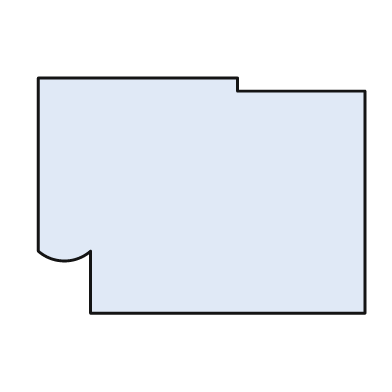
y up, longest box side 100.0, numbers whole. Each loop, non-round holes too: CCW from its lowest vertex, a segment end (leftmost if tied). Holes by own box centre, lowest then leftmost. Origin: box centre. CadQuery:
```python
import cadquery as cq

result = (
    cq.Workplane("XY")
    .moveTo(-34.0, -36.0)
    .lineTo(50.0, -36.0)
    .lineTo(50.0, 32.0)
    .lineTo(11.0, 32.0)
    .lineTo(11.0, 36.0)
    .lineTo(-50.0, 36.0)
    .lineTo(-50.0, -17.0)
    .threePointArc((-42.0, -20.0), (-34.0, -17.0))
    .close()
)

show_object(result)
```